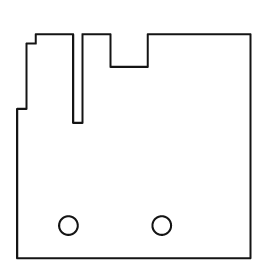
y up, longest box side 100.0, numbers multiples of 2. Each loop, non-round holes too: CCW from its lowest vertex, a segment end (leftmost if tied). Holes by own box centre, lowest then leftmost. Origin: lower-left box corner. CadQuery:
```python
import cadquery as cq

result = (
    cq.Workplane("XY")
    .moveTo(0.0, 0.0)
    .lineTo(100.0, 0.0)
    .lineTo(100.0, 96.0)
    .lineTo(56.0, 96.0)
    .lineTo(56.0, 82.0)
    .lineTo(40.0, 82.0)
    .lineTo(40.0, 96.0)
    .lineTo(28.0, 96.0)
    .lineTo(28.0, 58.0)
    .lineTo(24.0, 58.0)
    .lineTo(24.0, 96.0)
    .lineTo(8.0, 96.0)
    .lineTo(8.0, 92.0)
    .lineTo(4.0, 92.0)
    .lineTo(4.0, 64.0)
    .lineTo(0.0, 64.0)
    .close()
    .moveTo(22.0, 14.0)
    .circle(4.0)
    .moveTo(62.0, 14.0)
    .circle(4.0)
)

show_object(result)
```